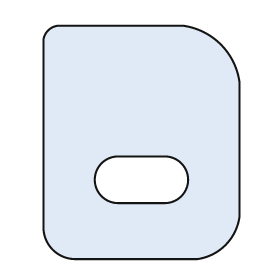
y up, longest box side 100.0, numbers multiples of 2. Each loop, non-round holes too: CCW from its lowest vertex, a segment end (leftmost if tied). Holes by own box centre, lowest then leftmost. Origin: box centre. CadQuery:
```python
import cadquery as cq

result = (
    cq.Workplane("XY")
    .moveTo(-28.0, -50.0)
    .lineTo(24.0, -50.0)
    .threePointArc((36.0, -44.0), (42.0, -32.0))
    .lineTo(42.0, 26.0)
    .threePointArc((34.0, 42.0), (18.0, 50.0))
    .lineTo(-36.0, 50.0)
    .threePointArc((-40.0, 48.0), (-42.0, 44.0))
    .lineTo(-42.0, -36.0)
    .threePointArc((-38.0, -46.0), (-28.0, -50.0))
    .close()
    .moveTo(-10.0, -26.0)
    .lineTo(10.0, -26.0)
    .threePointArc((20.0, -16.0), (10.0, -6.0))
    .lineTo(-10.0, -6.0)
    .threePointArc((-20.0, -16.0), (-10.0, -26.0))
    .close()
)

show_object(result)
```